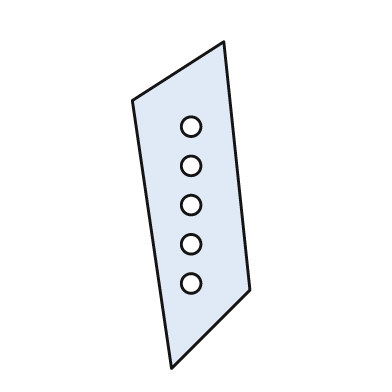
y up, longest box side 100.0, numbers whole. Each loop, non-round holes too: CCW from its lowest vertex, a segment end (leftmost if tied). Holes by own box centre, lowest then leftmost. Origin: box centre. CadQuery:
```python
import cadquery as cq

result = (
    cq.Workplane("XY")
    .moveTo(-6.0, -50.0)
    .lineTo(18.0, -26.0)
    .lineTo(10.0, 50.0)
    .lineTo(-18.0, 32.0)
    .close()
    .moveTo(0.0, -24.0)
    .circle(3.0)
    .moveTo(0.0, -12.0)
    .circle(3.0)
    .moveTo(0.0, 0.0)
    .circle(3.0)
    .moveTo(0.0, 12.0)
    .circle(3.0)
    .moveTo(0.0, 24.0)
    .circle(3.0)
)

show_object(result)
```